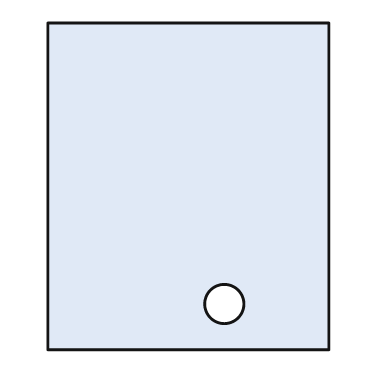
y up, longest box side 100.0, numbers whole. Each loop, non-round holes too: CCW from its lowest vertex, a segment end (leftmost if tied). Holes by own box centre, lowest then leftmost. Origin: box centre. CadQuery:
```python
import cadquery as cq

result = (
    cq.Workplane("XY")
    .moveTo(-43.0, -50.0)
    .lineTo(43.0, -50.0)
    .lineTo(43.0, 50.0)
    .lineTo(-43.0, 50.0)
    .close()
    .moveTo(11.0, -36.0)
    .circle(6.0)
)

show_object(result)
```